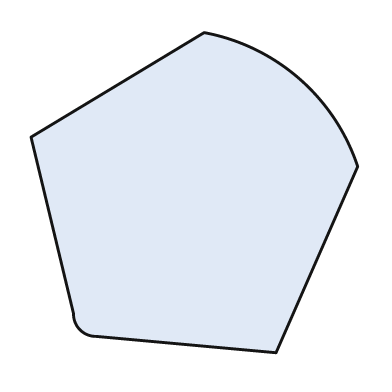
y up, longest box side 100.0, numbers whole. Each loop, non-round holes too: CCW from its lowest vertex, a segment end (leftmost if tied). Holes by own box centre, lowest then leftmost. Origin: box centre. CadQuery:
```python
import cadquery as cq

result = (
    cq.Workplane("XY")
    .moveTo(25.0, -49.0)
    .lineTo(50.0, 8.0)
    .threePointArc((32.0, 35.0), (3.0, 49.0))
    .lineTo(-50.0, 17.0)
    .lineTo(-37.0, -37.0)
    .threePointArc((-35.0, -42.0), (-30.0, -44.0))
    .close()
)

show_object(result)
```